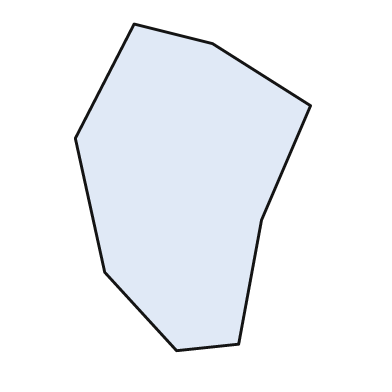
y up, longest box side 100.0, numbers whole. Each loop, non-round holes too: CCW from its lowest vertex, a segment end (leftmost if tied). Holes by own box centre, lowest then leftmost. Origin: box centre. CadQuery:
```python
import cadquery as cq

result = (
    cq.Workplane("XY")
    .moveTo(-5.0, -50.0)
    .lineTo(14.0, -48.0)
    .lineTo(21.0, -10.0)
    .lineTo(36.0, 25.0)
    .lineTo(6.0, 44.0)
    .lineTo(-18.0, 50.0)
    .lineTo(-36.0, 15.0)
    .lineTo(-27.0, -26.0)
    .close()
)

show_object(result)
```